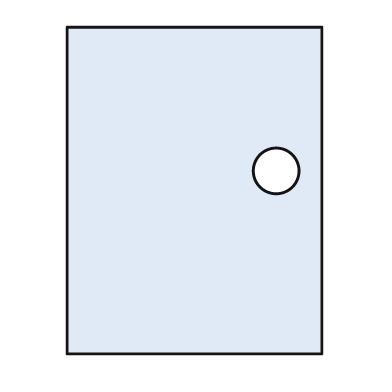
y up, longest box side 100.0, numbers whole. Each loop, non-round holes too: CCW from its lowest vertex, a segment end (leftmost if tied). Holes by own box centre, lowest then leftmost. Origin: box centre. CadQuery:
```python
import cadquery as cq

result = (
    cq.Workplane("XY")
    .moveTo(-39.0, -50.0)
    .lineTo(39.0, -50.0)
    .lineTo(39.0, 50.0)
    .lineTo(-39.0, 50.0)
    .close()
    .moveTo(25.0, 6.0)
    .circle(7.0)
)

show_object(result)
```